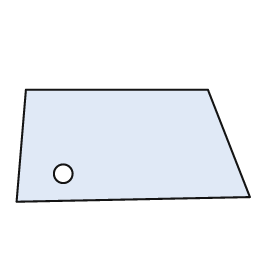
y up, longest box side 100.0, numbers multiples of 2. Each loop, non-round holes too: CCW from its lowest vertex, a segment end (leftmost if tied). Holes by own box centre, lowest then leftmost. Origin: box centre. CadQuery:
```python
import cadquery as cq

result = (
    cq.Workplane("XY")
    .moveTo(-50.0, -24.0)
    .lineTo(50.0, -22.0)
    .lineTo(32.0, 24.0)
    .lineTo(-46.0, 24.0)
    .close()
    .moveTo(-30.0, -12.0)
    .circle(4.0)
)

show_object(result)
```